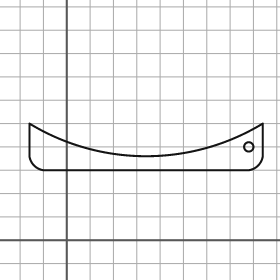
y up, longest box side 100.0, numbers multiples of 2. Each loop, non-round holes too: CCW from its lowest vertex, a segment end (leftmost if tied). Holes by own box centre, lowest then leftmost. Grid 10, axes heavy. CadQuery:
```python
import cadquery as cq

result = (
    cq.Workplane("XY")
    .moveTo(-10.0, 30.0)
    .lineTo(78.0, 30.0)
    .threePointArc((82.0, 32.0), (84.0, 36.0))
    .lineTo(84.0, 50.0)
    .threePointArc((34.0, 36.0), (-16.0, 50.0))
    .lineTo(-16.0, 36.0)
    .threePointArc((-14.0, 32.0), (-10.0, 30.0))
    .close()
    .moveTo(78.0, 40.0)
    .circle(2.0)
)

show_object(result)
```